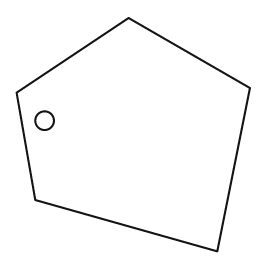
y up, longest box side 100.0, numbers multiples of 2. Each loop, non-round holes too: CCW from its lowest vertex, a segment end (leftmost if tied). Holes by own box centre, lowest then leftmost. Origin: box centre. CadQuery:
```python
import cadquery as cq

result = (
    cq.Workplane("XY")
    .moveTo(36.0, -50.0)
    .lineTo(50.0, 20.0)
    .lineTo(-2.0, 50.0)
    .lineTo(-50.0, 18.0)
    .lineTo(-42.0, -28.0)
    .close()
    .moveTo(-38.0, 6.0)
    .circle(4.0)
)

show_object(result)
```